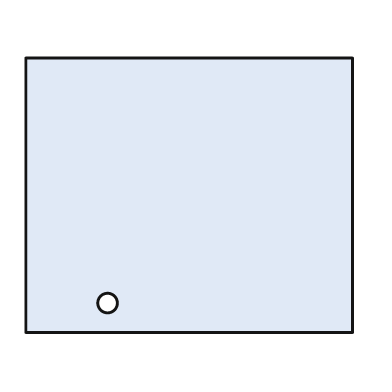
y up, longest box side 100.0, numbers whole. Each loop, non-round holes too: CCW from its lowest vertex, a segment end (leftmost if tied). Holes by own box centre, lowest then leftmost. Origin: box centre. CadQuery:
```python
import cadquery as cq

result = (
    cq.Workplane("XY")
    .moveTo(-50.0, -42.0)
    .lineTo(50.0, -42.0)
    .lineTo(50.0, 42.0)
    .lineTo(-50.0, 42.0)
    .close()
    .moveTo(-25.0, -33.0)
    .circle(3.0)
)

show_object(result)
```